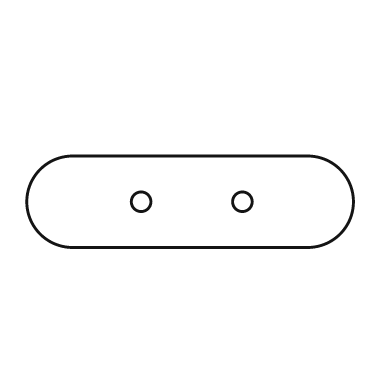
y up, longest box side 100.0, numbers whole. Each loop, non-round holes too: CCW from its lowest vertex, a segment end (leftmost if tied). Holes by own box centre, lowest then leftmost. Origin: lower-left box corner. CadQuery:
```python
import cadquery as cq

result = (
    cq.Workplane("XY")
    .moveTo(14.0, 0.0)
    .lineTo(86.0, 0.0)
    .threePointArc((100.0, 14.0), (86.0, 28.0))
    .lineTo(14.0, 28.0)
    .threePointArc((0.0, 14.0), (14.0, 0.0))
    .close()
    .moveTo(35.0, 14.0)
    .circle(3.0)
    .moveTo(66.0, 14.0)
    .circle(3.0)
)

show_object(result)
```